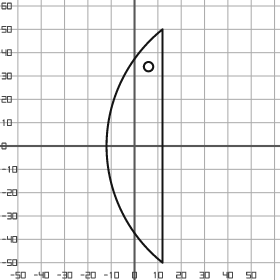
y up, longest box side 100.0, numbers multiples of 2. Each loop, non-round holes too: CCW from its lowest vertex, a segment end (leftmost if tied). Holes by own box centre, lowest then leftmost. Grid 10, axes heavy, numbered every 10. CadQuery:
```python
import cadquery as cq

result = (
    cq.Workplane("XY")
    .moveTo(12.0, -50.0)
    .lineTo(12.0, 50.0)
    .threePointArc((-12.0, 0.0), (12.0, -50.0))
    .close()
    .moveTo(6.0, 34.0)
    .circle(2.0)
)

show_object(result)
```